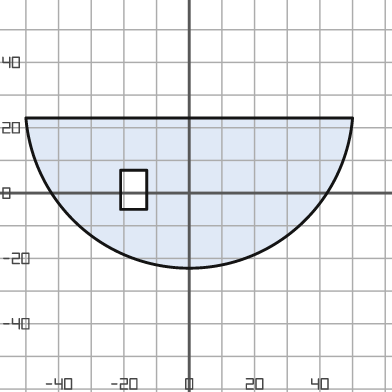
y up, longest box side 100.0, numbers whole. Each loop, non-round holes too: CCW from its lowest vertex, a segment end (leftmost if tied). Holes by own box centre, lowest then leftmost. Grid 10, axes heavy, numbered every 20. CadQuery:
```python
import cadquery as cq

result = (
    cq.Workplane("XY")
    .moveTo(-50.0, 23.0)
    .threePointArc((0.0, -23.0), (50.0, 23.0))
    .close()
    .moveTo(-21.0, -5.0)
    .lineTo(-13.0, -5.0)
    .lineTo(-13.0, 7.0)
    .lineTo(-21.0, 7.0)
    .close()
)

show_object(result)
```